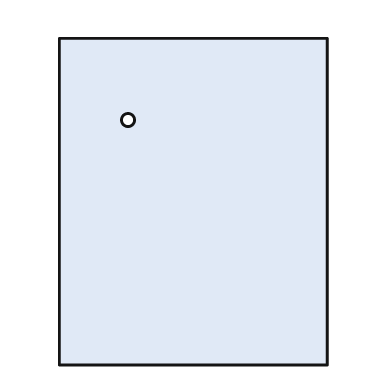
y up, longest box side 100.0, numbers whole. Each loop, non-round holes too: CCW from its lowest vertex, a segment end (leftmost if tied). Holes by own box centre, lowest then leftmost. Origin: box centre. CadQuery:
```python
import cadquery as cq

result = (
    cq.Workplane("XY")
    .moveTo(-41.0, -50.0)
    .lineTo(41.0, -50.0)
    .lineTo(41.0, 50.0)
    .lineTo(-41.0, 50.0)
    .close()
    .moveTo(-20.0, 25.0)
    .circle(2.0)
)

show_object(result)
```